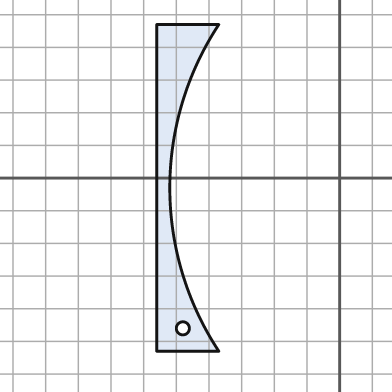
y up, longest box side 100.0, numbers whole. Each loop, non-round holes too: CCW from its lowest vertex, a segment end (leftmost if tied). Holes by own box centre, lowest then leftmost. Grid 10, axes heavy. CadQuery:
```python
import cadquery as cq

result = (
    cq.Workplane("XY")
    .moveTo(-56.0, -53.0)
    .lineTo(-37.0, -53.0)
    .threePointArc((-52.0, -3.0), (-37.0, 47.0))
    .lineTo(-56.0, 47.0)
    .close()
    .moveTo(-48.0, -46.0)
    .circle(2.0)
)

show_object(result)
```